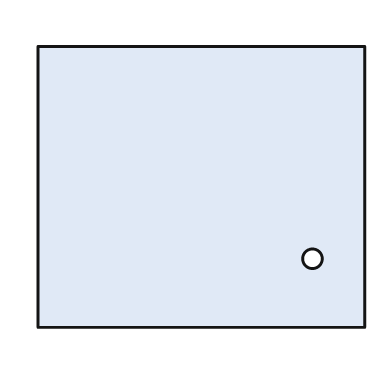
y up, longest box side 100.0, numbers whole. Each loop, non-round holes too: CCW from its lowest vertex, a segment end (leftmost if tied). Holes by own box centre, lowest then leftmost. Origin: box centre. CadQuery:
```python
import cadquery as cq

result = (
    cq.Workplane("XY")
    .moveTo(-50.0, -43.0)
    .lineTo(50.0, -43.0)
    .lineTo(50.0, 43.0)
    .lineTo(-50.0, 43.0)
    .close()
    .moveTo(34.0, -22.0)
    .circle(3.0)
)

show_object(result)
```